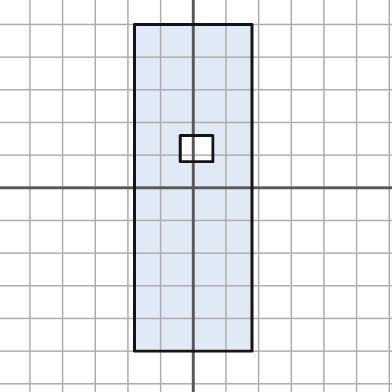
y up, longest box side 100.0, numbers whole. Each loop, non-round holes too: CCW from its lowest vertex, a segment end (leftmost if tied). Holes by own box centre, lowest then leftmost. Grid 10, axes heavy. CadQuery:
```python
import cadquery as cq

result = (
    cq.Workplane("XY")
    .moveTo(-18.0, -50.0)
    .lineTo(18.0, -50.0)
    .lineTo(18.0, 50.0)
    .lineTo(-18.0, 50.0)
    .close()
    .moveTo(-4.0, 8.0)
    .lineTo(6.0, 8.0)
    .lineTo(6.0, 16.0)
    .lineTo(-4.0, 16.0)
    .close()
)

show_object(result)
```